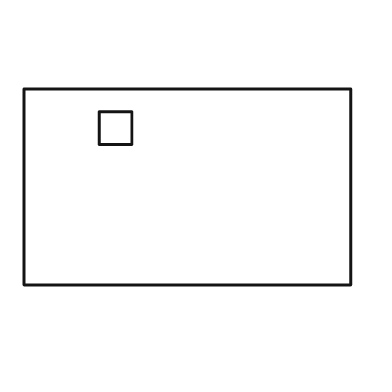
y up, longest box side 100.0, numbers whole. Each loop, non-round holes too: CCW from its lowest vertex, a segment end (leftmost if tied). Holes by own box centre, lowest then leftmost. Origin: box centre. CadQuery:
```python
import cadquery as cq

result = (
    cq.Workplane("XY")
    .moveTo(-50.0, -30.0)
    .lineTo(50.0, -30.0)
    .lineTo(50.0, 30.0)
    .lineTo(-50.0, 30.0)
    .close()
    .moveTo(-27.0, 13.0)
    .lineTo(-17.0, 13.0)
    .lineTo(-17.0, 23.0)
    .lineTo(-27.0, 23.0)
    .close()
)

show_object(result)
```